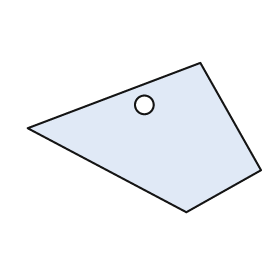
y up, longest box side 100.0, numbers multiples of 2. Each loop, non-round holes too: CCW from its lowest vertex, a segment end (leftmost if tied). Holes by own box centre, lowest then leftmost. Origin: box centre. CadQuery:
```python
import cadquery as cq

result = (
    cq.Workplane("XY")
    .moveTo(18.0, -32.0)
    .lineTo(50.0, -14.0)
    .lineTo(24.0, 32.0)
    .lineTo(-50.0, 4.0)
    .close()
    .moveTo(0.0, 14.0)
    .circle(4.0)
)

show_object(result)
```